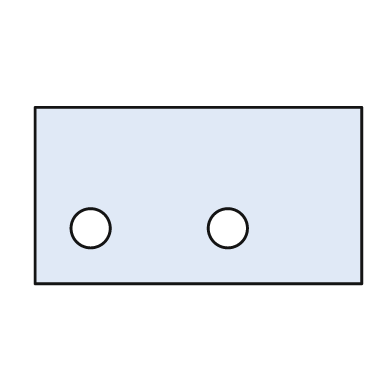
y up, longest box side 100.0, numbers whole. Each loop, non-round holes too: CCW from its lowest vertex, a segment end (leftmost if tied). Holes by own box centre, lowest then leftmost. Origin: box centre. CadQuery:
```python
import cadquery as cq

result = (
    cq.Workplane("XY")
    .moveTo(-50.0, -27.0)
    .lineTo(50.0, -27.0)
    .lineTo(50.0, 27.0)
    .lineTo(-50.0, 27.0)
    .close()
    .moveTo(-33.0, -10.0)
    .circle(6.0)
    .moveTo(9.0, -10.0)
    .circle(6.0)
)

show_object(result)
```